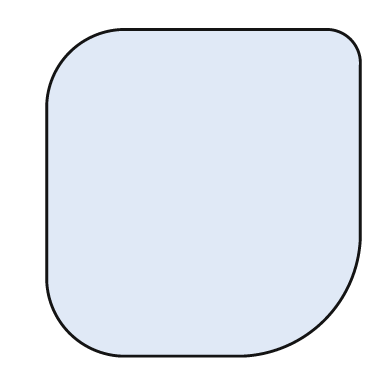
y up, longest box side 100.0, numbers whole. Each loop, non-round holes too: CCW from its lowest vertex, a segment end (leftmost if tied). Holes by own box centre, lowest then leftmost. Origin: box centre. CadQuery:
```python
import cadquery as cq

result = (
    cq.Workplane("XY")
    .moveTo(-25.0, -50.0)
    .lineTo(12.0, -50.0)
    .threePointArc((37.0, -39.0), (48.0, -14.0))
    .lineTo(48.0, 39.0)
    .threePointArc((45.0, 47.0), (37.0, 50.0))
    .lineTo(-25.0, 50.0)
    .threePointArc((-41.0, 43.0), (-48.0, 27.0))
    .lineTo(-48.0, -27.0)
    .threePointArc((-41.0, -43.0), (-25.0, -50.0))
    .close()
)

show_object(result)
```